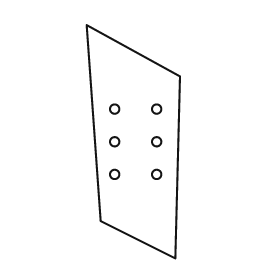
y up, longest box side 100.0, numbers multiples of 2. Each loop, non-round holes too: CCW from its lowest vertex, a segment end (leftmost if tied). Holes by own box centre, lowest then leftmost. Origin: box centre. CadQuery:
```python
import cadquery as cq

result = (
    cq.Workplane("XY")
    .moveTo(18.0, -50.0)
    .lineTo(20.0, 28.0)
    .lineTo(-20.0, 50.0)
    .lineTo(-14.0, -34.0)
    .close()
    .moveTo(-8.0, -14.0)
    .circle(2.0)
    .moveTo(10.0, -14.0)
    .circle(2.0)
    .moveTo(-8.0, 0.0)
    .circle(2.0)
    .moveTo(10.0, 0.0)
    .circle(2.0)
    .moveTo(-8.0, 14.0)
    .circle(2.0)
    .moveTo(10.0, 14.0)
    .circle(2.0)
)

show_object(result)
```